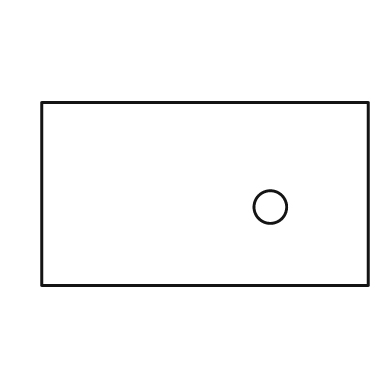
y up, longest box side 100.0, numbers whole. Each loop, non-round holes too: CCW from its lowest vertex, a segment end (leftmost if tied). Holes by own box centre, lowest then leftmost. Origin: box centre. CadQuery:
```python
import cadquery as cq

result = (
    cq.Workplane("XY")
    .moveTo(-50.0, -28.0)
    .lineTo(50.0, -28.0)
    .lineTo(50.0, 28.0)
    .lineTo(-50.0, 28.0)
    .close()
    .moveTo(20.0, -4.0)
    .circle(5.0)
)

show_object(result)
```